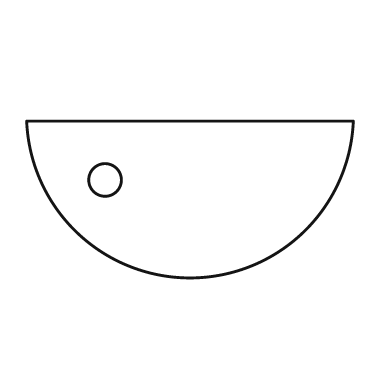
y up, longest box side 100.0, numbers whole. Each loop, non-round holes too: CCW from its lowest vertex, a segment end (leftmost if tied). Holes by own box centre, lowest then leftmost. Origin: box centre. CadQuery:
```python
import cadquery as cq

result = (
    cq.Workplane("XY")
    .moveTo(-50.0, 24.0)
    .threePointArc((0.0, -24.0), (50.0, 24.0))
    .close()
    .moveTo(-26.0, 6.0)
    .circle(5.0)
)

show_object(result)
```